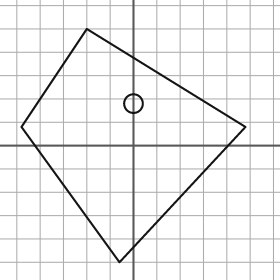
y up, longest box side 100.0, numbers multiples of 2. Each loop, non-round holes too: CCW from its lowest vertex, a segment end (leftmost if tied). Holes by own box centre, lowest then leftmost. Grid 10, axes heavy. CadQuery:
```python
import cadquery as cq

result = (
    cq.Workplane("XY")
    .moveTo(-6.0, -50.0)
    .lineTo(48.0, 8.0)
    .lineTo(-20.0, 50.0)
    .lineTo(-48.0, 8.0)
    .close()
    .moveTo(0.0, 18.0)
    .circle(4.0)
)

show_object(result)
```